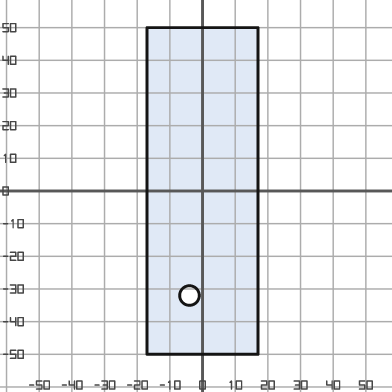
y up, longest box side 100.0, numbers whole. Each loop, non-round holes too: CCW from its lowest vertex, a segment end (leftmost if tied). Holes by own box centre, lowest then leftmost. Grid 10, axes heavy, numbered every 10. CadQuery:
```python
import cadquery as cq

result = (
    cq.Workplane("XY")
    .moveTo(-17.0, -50.0)
    .lineTo(17.0, -50.0)
    .lineTo(17.0, 50.0)
    .lineTo(-17.0, 50.0)
    .close()
    .moveTo(-4.0, -32.0)
    .circle(3.0)
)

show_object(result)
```